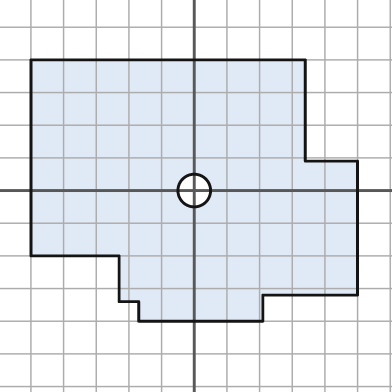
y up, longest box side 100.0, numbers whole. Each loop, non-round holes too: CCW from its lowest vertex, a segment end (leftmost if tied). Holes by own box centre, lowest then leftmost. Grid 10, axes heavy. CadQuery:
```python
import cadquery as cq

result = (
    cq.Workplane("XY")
    .moveTo(-17.0, -40.0)
    .lineTo(21.0, -40.0)
    .lineTo(21.0, -32.0)
    .lineTo(50.0, -32.0)
    .lineTo(50.0, 9.0)
    .lineTo(34.0, 9.0)
    .lineTo(34.0, 40.0)
    .lineTo(-50.0, 40.0)
    .lineTo(-50.0, -20.0)
    .lineTo(-23.0, -20.0)
    .lineTo(-23.0, -34.0)
    .lineTo(-17.0, -34.0)
    .close()
    .moveTo(0.0, 0.0)
    .circle(5.0)
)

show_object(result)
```